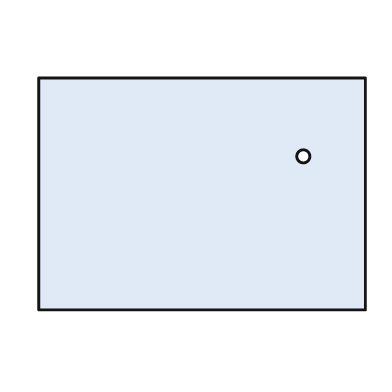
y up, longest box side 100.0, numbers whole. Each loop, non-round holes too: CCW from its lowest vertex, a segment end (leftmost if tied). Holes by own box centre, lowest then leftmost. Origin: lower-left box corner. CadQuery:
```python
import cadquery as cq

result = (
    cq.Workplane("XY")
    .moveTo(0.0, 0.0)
    .lineTo(100.0, 0.0)
    .lineTo(100.0, 71.0)
    .lineTo(0.0, 71.0)
    .close()
    .moveTo(81.0, 47.0)
    .circle(2.0)
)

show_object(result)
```